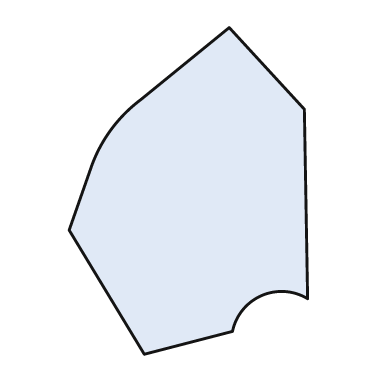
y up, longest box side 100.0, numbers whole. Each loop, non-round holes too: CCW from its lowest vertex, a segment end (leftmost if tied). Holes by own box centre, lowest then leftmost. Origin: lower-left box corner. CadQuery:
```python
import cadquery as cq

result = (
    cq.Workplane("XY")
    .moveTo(23.0, 0.0)
    .lineTo(50.0, 7.0)
    .threePointArc((59.0, 18.0), (73.0, 17.0))
    .lineTo(72.0, 75.0)
    .lineTo(49.0, 100.0)
    .lineTo(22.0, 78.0)
    .threePointArc((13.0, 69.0), (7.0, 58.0))
    .lineTo(0.0, 38.0)
    .close()
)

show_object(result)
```